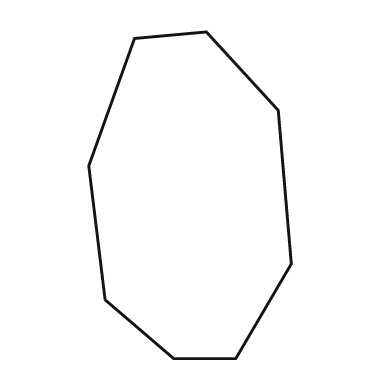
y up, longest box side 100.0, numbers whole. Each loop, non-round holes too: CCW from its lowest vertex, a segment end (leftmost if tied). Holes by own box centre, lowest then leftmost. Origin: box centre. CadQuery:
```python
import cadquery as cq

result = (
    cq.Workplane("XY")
    .moveTo(-5.0, -50.0)
    .lineTo(14.0, -50.0)
    .lineTo(31.0, -21.0)
    .lineTo(27.0, 26.0)
    .lineTo(5.0, 50.0)
    .lineTo(-17.0, 48.0)
    .lineTo(-31.0, 9.0)
    .lineTo(-26.0, -32.0)
    .close()
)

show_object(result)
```